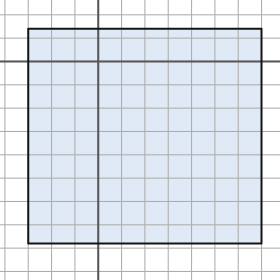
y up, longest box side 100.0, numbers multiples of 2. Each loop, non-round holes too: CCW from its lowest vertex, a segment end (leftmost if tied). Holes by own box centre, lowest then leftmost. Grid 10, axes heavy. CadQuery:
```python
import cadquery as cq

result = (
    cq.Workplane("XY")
    .moveTo(-30.0, -78.0)
    .lineTo(70.0, -78.0)
    .lineTo(70.0, 14.0)
    .lineTo(-30.0, 14.0)
    .close()
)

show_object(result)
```